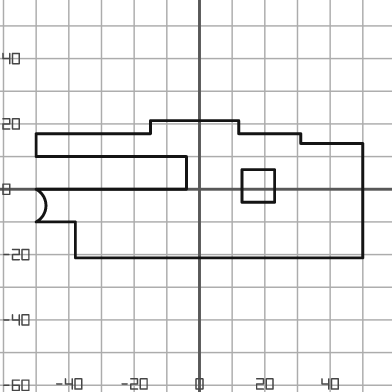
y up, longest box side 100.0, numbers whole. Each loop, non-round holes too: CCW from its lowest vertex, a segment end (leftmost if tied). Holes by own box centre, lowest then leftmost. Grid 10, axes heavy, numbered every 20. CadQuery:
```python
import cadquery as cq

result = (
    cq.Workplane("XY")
    .moveTo(-38.0, -21.0)
    .lineTo(50.0, -21.0)
    .lineTo(50.0, 14.0)
    .lineTo(31.0, 14.0)
    .lineTo(31.0, 17.0)
    .lineTo(12.0, 17.0)
    .lineTo(12.0, 21.0)
    .lineTo(-15.0, 21.0)
    .lineTo(-15.0, 17.0)
    .lineTo(-50.0, 17.0)
    .lineTo(-50.0, 10.0)
    .lineTo(-4.0, 10.0)
    .lineTo(-4.0, 0.0)
    .lineTo(-50.0, 0.0)
    .threePointArc((-47.0, -5.0), (-50.0, -10.0))
    .lineTo(-38.0, -10.0)
    .close()
    .moveTo(13.0, -4.0)
    .lineTo(23.0, -4.0)
    .lineTo(23.0, 6.0)
    .lineTo(13.0, 6.0)
    .close()
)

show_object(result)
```